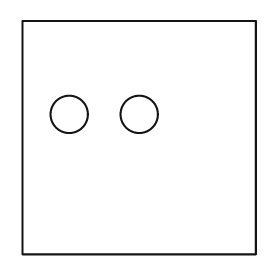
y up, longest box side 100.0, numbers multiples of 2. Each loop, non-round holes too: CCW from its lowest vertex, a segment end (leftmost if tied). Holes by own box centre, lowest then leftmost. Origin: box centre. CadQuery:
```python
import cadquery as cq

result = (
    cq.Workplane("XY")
    .moveTo(-50.0, -50.0)
    .lineTo(50.0, -50.0)
    .lineTo(50.0, 50.0)
    .lineTo(-50.0, 50.0)
    .close()
    .moveTo(-30.0, 10.0)
    .circle(8.0)
    .moveTo(0.0, 10.0)
    .circle(8.0)
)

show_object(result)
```